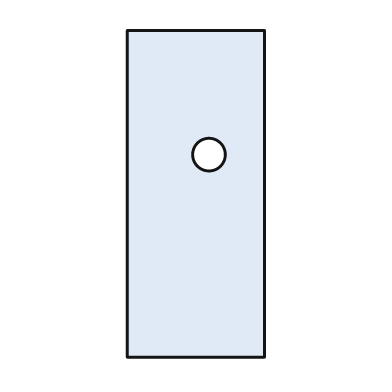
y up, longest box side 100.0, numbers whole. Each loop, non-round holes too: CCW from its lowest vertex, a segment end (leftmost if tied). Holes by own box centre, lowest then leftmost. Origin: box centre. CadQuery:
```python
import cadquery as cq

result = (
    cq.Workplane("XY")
    .moveTo(-21.0, -50.0)
    .lineTo(21.0, -50.0)
    .lineTo(21.0, 50.0)
    .lineTo(-21.0, 50.0)
    .close()
    .moveTo(4.0, 12.0)
    .circle(5.0)
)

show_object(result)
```